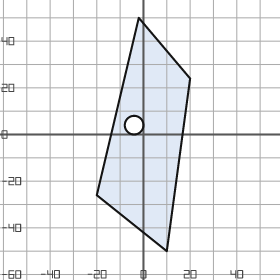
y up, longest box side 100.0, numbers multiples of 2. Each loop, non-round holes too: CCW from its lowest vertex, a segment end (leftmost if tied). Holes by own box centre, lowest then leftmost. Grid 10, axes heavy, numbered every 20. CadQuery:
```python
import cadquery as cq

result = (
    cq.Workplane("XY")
    .moveTo(10.0, -50.0)
    .lineTo(20.0, 24.0)
    .lineTo(-2.0, 50.0)
    .lineTo(-20.0, -26.0)
    .close()
    .moveTo(-4.0, 4.0)
    .circle(4.0)
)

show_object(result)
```